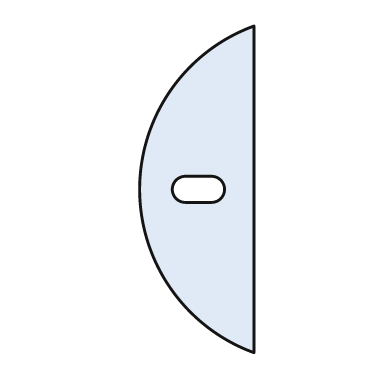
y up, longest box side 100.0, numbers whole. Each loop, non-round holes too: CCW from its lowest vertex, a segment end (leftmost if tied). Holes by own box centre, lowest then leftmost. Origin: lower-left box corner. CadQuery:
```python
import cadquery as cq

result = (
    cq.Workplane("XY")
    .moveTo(35.0, 0.0)
    .lineTo(35.0, 100.0)
    .threePointArc((0.0, 50.0), (35.0, 0.0))
    .close()
    .moveTo(14.0, 46.0)
    .lineTo(22.0, 46.0)
    .threePointArc((26.0, 50.0), (22.0, 54.0))
    .lineTo(14.0, 54.0)
    .threePointArc((10.0, 50.0), (14.0, 46.0))
    .close()
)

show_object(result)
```